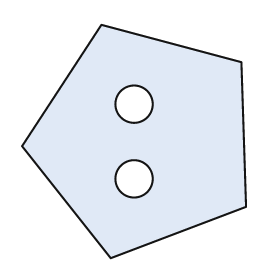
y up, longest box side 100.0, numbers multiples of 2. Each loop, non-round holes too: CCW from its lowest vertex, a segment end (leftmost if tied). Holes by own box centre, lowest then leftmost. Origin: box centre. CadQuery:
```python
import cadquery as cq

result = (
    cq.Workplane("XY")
    .moveTo(-10.0, -50.0)
    .lineTo(48.0, -28.0)
    .lineTo(46.0, 34.0)
    .lineTo(-14.0, 50.0)
    .lineTo(-48.0, -2.0)
    .close()
    .moveTo(0.0, -16.0)
    .circle(8.0)
    .moveTo(0.0, 16.0)
    .circle(8.0)
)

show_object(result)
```